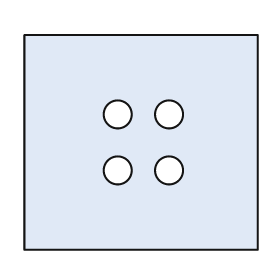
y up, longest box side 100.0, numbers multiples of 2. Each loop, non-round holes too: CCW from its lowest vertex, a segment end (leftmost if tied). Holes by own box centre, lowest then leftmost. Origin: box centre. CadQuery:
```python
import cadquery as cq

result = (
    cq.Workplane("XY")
    .moveTo(-50.0, -46.0)
    .lineTo(50.0, -46.0)
    .lineTo(50.0, 46.0)
    .lineTo(-50.0, 46.0)
    .close()
    .moveTo(-10.0, -12.0)
    .circle(6.0)
    .moveTo(12.0, -12.0)
    .circle(6.0)
    .moveTo(-10.0, 12.0)
    .circle(6.0)
    .moveTo(12.0, 12.0)
    .circle(6.0)
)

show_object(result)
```